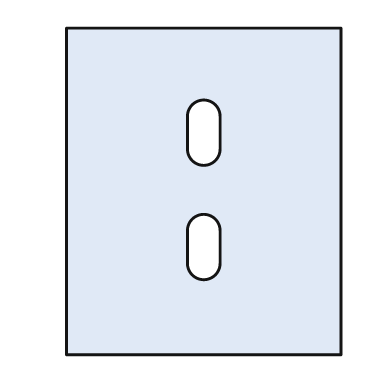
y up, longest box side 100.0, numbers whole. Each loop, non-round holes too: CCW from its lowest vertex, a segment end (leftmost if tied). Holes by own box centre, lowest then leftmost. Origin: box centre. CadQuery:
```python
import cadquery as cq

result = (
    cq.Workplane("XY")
    .moveTo(-42.0, -50.0)
    .lineTo(42.0, -50.0)
    .lineTo(42.0, 50.0)
    .lineTo(-42.0, 50.0)
    .close()
    .moveTo(-5.0, -22.0)
    .threePointArc((0.0, -27.0), (5.0, -22.0))
    .lineTo(5.0, -12.0)
    .threePointArc((0.0, -7.0), (-5.0, -12.0))
    .close()
    .moveTo(-5.0, 13.0)
    .threePointArc((0.0, 8.0), (5.0, 13.0))
    .lineTo(5.0, 23.0)
    .threePointArc((0.0, 28.0), (-5.0, 23.0))
    .close()
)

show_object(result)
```